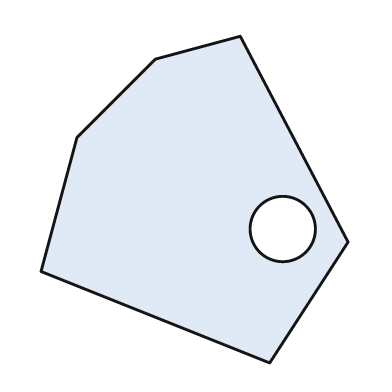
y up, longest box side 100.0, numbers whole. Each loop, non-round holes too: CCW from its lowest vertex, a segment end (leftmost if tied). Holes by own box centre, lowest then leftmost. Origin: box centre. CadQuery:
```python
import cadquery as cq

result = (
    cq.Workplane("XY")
    .moveTo(23.0, -50.0)
    .lineTo(47.0, -13.0)
    .lineTo(14.0, 50.0)
    .lineTo(-12.0, 43.0)
    .lineTo(-36.0, 19.0)
    .lineTo(-47.0, -22.0)
    .close()
    .moveTo(27.0, -9.0)
    .circle(10.0)
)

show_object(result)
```